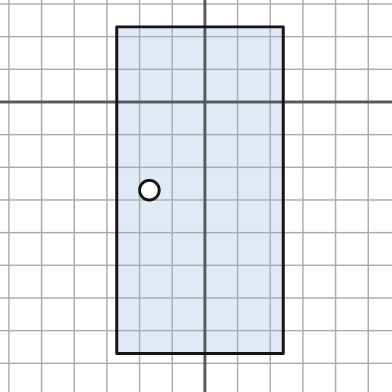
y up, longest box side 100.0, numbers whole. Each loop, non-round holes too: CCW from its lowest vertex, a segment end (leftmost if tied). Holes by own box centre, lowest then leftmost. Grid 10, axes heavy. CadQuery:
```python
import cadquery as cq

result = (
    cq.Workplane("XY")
    .moveTo(-27.0, -77.0)
    .lineTo(24.0, -77.0)
    .lineTo(24.0, 23.0)
    .lineTo(-27.0, 23.0)
    .close()
    .moveTo(-17.0, -27.0)
    .circle(3.0)
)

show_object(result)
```